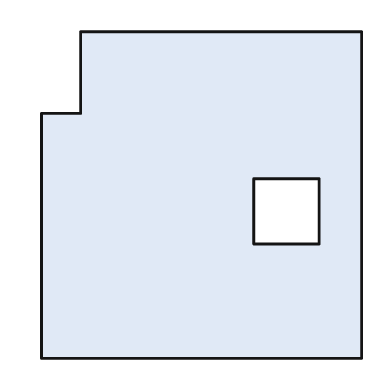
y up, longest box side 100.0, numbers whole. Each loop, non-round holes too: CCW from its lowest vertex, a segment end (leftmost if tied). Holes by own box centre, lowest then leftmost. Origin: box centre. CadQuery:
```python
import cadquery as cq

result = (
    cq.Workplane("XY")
    .moveTo(-49.0, -50.0)
    .lineTo(49.0, -50.0)
    .lineTo(49.0, 50.0)
    .lineTo(-37.0, 50.0)
    .lineTo(-37.0, 25.0)
    .lineTo(-49.0, 25.0)
    .close()
    .moveTo(16.0, -15.0)
    .lineTo(36.0, -15.0)
    .lineTo(36.0, 5.0)
    .lineTo(16.0, 5.0)
    .close()
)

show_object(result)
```